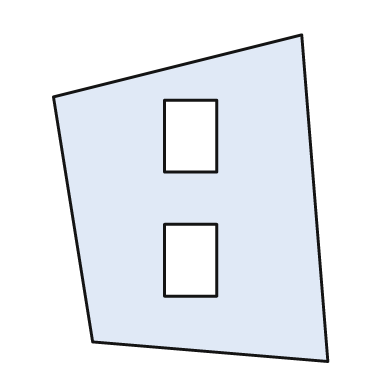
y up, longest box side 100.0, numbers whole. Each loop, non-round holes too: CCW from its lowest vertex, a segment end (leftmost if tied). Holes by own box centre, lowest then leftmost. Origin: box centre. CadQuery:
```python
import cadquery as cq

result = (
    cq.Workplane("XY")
    .moveTo(42.0, -50.0)
    .lineTo(34.0, 50.0)
    .lineTo(-42.0, 31.0)
    .lineTo(-30.0, -44.0)
    .close()
    .moveTo(-8.0, -30.0)
    .lineTo(8.0, -30.0)
    .lineTo(8.0, -8.0)
    .lineTo(-8.0, -8.0)
    .close()
    .moveTo(-8.0, 8.0)
    .lineTo(8.0, 8.0)
    .lineTo(8.0, 30.0)
    .lineTo(-8.0, 30.0)
    .close()
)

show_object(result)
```